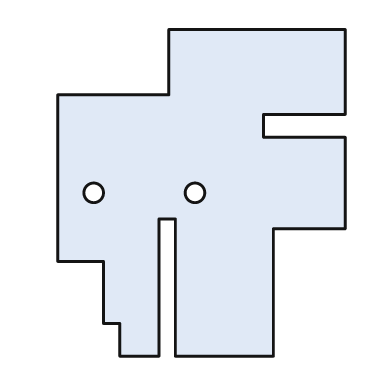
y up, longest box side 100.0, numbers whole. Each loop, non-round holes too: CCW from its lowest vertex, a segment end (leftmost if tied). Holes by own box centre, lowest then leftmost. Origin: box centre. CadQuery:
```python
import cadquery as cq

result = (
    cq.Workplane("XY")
    .moveTo(-25.0, -50.0)
    .lineTo(-13.0, -50.0)
    .lineTo(-13.0, -8.0)
    .lineTo(-8.0, -8.0)
    .lineTo(-8.0, -50.0)
    .lineTo(22.0, -50.0)
    .lineTo(22.0, -11.0)
    .lineTo(44.0, -11.0)
    .lineTo(44.0, 17.0)
    .lineTo(19.0, 17.0)
    .lineTo(19.0, 24.0)
    .lineTo(44.0, 24.0)
    .lineTo(44.0, 50.0)
    .lineTo(-10.0, 50.0)
    .lineTo(-10.0, 30.0)
    .lineTo(-44.0, 30.0)
    .lineTo(-44.0, -21.0)
    .lineTo(-30.0, -21.0)
    .lineTo(-30.0, -40.0)
    .lineTo(-25.0, -40.0)
    .close()
    .moveTo(-33.0, 0.0)
    .circle(3.0)
    .moveTo(-2.0, 0.0)
    .circle(3.0)
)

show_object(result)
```